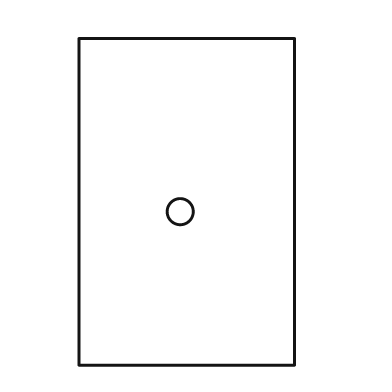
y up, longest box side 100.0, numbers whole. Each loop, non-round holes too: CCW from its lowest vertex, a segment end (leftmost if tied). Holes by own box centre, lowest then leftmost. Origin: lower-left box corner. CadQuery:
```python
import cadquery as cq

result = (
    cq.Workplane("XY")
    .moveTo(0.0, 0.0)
    .lineTo(66.0, 0.0)
    .lineTo(66.0, 100.0)
    .lineTo(0.0, 100.0)
    .close()
    .moveTo(31.0, 47.0)
    .circle(4.0)
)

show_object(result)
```